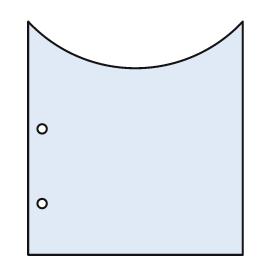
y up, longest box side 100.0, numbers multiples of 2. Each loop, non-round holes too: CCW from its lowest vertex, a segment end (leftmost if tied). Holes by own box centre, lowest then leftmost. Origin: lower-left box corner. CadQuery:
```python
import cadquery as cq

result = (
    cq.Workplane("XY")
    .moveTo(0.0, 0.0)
    .lineTo(92.0, 0.0)
    .lineTo(92.0, 100.0)
    .threePointArc((46.0, 80.0), (0.0, 100.0))
    .close()
    .moveTo(6.0, 22.0)
    .circle(2.0)
    .moveTo(6.0, 54.0)
    .circle(2.0)
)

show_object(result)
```